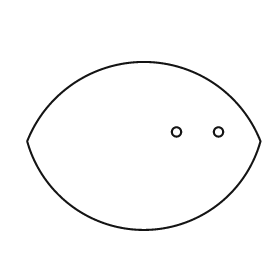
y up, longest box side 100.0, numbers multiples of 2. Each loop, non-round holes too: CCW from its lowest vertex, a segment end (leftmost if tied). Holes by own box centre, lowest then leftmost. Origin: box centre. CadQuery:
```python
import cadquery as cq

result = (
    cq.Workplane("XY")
    .moveTo(-50.0, 2.0)
    .threePointArc((0.0, -36.0), (50.0, 2.0))
    .threePointArc((0.0, 36.0), (-50.0, 2.0))
    .close()
    .moveTo(14.0, 6.0)
    .circle(2.0)
    .moveTo(32.0, 6.0)
    .circle(2.0)
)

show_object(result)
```